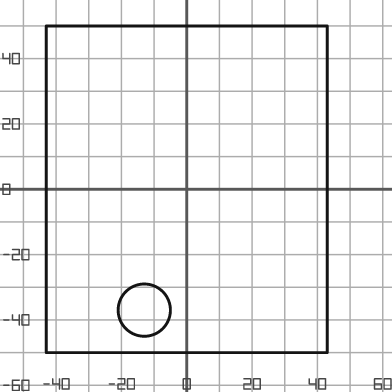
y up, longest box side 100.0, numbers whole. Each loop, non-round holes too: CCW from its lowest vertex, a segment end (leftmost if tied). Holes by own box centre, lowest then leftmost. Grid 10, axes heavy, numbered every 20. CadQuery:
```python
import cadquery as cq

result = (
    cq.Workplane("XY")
    .moveTo(-43.0, -50.0)
    .lineTo(43.0, -50.0)
    .lineTo(43.0, 50.0)
    .lineTo(-43.0, 50.0)
    .close()
    .moveTo(-13.0, -37.0)
    .circle(8.0)
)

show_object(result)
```